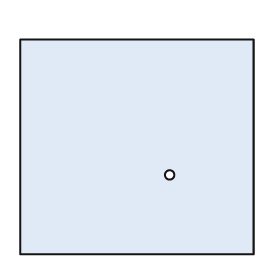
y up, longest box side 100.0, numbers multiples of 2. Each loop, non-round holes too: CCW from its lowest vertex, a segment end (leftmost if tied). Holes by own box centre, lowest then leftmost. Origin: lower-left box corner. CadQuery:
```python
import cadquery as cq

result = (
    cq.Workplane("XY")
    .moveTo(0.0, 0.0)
    .lineTo(100.0, 0.0)
    .lineTo(100.0, 92.0)
    .lineTo(0.0, 92.0)
    .close()
    .moveTo(64.0, 34.0)
    .circle(2.0)
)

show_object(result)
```